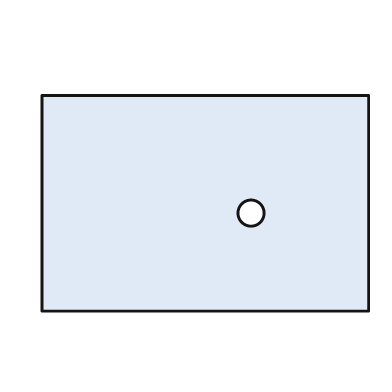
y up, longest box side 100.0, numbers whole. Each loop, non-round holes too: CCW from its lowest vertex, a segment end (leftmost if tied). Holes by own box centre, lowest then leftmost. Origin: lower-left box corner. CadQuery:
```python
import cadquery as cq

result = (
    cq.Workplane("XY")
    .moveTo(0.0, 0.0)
    .lineTo(100.0, 0.0)
    .lineTo(100.0, 66.0)
    .lineTo(0.0, 66.0)
    .close()
    .moveTo(64.0, 30.0)
    .circle(4.0)
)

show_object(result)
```